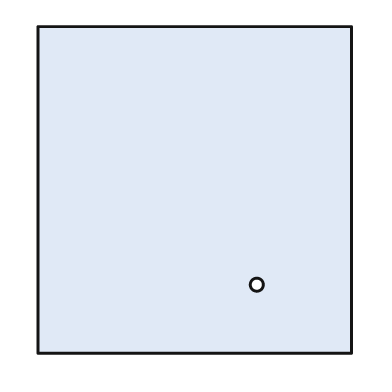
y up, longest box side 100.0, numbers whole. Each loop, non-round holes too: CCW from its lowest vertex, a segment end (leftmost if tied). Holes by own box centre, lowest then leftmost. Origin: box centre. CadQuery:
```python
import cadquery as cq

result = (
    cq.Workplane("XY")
    .moveTo(-48.0, -50.0)
    .lineTo(48.0, -50.0)
    .lineTo(48.0, 50.0)
    .lineTo(-48.0, 50.0)
    .close()
    .moveTo(19.0, -29.0)
    .circle(2.0)
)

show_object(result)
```